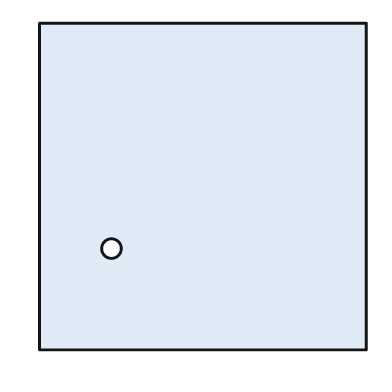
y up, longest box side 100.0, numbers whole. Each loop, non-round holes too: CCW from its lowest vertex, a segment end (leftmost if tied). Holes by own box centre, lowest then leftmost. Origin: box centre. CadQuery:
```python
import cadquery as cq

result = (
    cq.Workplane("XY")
    .moveTo(-50.0, -50.0)
    .lineTo(50.0, -50.0)
    .lineTo(50.0, 50.0)
    .lineTo(-50.0, 50.0)
    .close()
    .moveTo(-28.0, -19.0)
    .circle(3.0)
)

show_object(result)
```